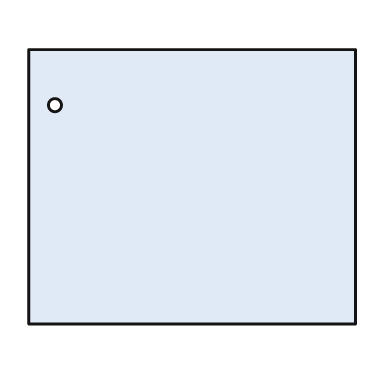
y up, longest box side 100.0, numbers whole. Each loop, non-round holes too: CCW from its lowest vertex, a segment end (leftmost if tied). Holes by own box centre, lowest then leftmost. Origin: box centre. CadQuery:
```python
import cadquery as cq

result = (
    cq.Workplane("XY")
    .moveTo(-50.0, -42.0)
    .lineTo(50.0, -42.0)
    .lineTo(50.0, 42.0)
    .lineTo(-50.0, 42.0)
    .close()
    .moveTo(-42.0, 25.0)
    .circle(2.0)
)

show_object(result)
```